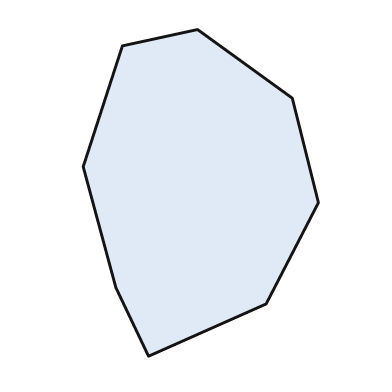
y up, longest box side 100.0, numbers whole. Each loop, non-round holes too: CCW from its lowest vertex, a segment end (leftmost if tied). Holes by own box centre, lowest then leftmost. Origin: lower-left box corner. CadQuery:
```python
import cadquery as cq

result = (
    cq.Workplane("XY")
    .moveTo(20.0, 0.0)
    .lineTo(56.0, 16.0)
    .lineTo(72.0, 47.0)
    .lineTo(64.0, 79.0)
    .lineTo(35.0, 100.0)
    .lineTo(12.0, 95.0)
    .lineTo(0.0, 58.0)
    .lineTo(10.0, 21.0)
    .close()
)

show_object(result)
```